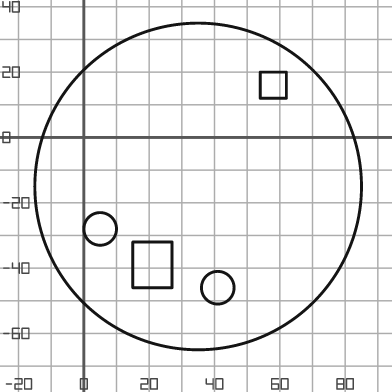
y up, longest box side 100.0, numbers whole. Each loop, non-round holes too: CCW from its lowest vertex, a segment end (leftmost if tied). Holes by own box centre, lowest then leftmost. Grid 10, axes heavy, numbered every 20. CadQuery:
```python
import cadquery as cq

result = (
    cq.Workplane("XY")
    .moveTo(35.0, -15.0)
    .circle(50.0)
    .moveTo(41.0, -46.0)
    .circle(5.0)
    .moveTo(15.0, -46.0)
    .lineTo(27.0, -46.0)
    .lineTo(27.0, -32.0)
    .lineTo(15.0, -32.0)
    .close()
    .moveTo(5.0, -28.0)
    .circle(5.0)
    .moveTo(54.0, 12.0)
    .lineTo(62.0, 12.0)
    .lineTo(62.0, 20.0)
    .lineTo(54.0, 20.0)
    .close()
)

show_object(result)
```